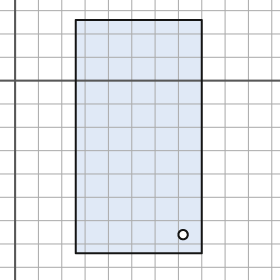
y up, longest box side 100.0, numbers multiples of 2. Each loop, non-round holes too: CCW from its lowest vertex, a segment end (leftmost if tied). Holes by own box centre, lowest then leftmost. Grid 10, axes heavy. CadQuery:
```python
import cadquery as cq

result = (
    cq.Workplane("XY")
    .moveTo(26.0, -74.0)
    .lineTo(80.0, -74.0)
    .lineTo(80.0, 26.0)
    .lineTo(26.0, 26.0)
    .close()
    .moveTo(72.0, -66.0)
    .circle(2.0)
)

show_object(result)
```